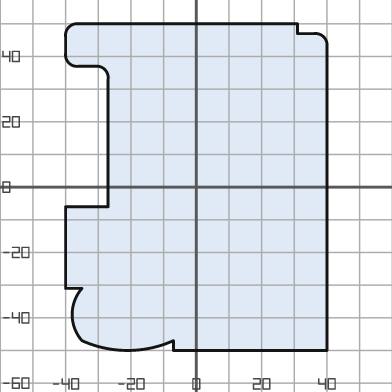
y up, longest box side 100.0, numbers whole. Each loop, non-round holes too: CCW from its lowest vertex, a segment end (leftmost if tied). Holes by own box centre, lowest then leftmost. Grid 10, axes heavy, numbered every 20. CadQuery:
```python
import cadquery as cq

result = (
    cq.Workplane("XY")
    .moveTo(-7.0, -50.0)
    .lineTo(40.0, -50.0)
    .lineTo(40.0, 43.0)
    .threePointArc((39.0, 46.0), (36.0, 47.0))
    .lineTo(31.0, 47.0)
    .lineTo(31.0, 50.0)
    .lineTo(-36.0, 50.0)
    .threePointArc((-39.0, 49.0), (-40.0, 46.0))
    .lineTo(-40.0, 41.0)
    .threePointArc((-39.0, 38.0), (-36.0, 37.0))
    .lineTo(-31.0, 37.0)
    .threePointArc((-28.0, 36.0), (-27.0, 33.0))
    .lineTo(-27.0, -6.0)
    .lineTo(-40.0, -6.0)
    .lineTo(-40.0, -31.0)
    .lineTo(-35.0, -31.0)
    .threePointArc((-38.0, -39.0), (-35.0, -47.0))
    .threePointArc((-21.0, -50.0), (-7.0, -47.0))
    .close()
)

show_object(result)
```